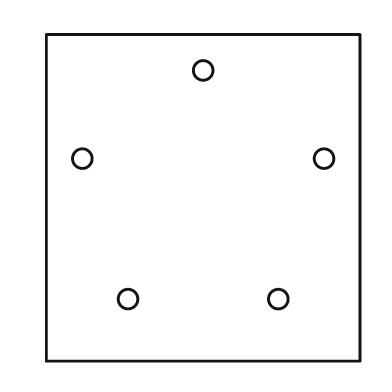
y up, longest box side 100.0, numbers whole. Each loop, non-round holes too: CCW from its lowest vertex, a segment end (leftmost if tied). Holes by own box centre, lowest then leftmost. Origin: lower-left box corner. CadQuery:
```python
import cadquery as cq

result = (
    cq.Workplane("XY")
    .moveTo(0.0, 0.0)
    .lineTo(96.0, 0.0)
    .lineTo(96.0, 100.0)
    .lineTo(0.0, 100.0)
    .close()
    .moveTo(25.0, 19.0)
    .circle(3.0)
    .moveTo(71.0, 19.0)
    .circle(3.0)
    .moveTo(11.0, 62.0)
    .circle(3.0)
    .moveTo(85.0, 62.0)
    .circle(3.0)
    .moveTo(48.0, 89.0)
    .circle(3.0)
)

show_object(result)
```